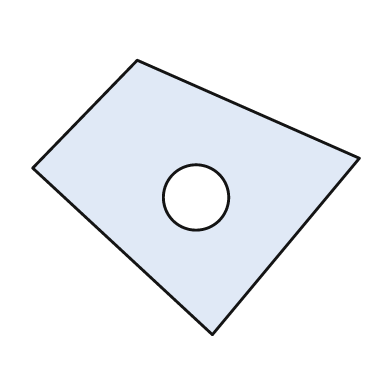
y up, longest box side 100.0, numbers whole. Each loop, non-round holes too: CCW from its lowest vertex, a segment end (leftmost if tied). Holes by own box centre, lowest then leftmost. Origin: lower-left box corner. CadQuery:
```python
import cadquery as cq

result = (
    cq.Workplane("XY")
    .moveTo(55.0, 0.0)
    .lineTo(100.0, 54.0)
    .lineTo(32.0, 84.0)
    .lineTo(0.0, 51.0)
    .close()
    .moveTo(50.0, 42.0)
    .circle(10.0)
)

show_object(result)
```